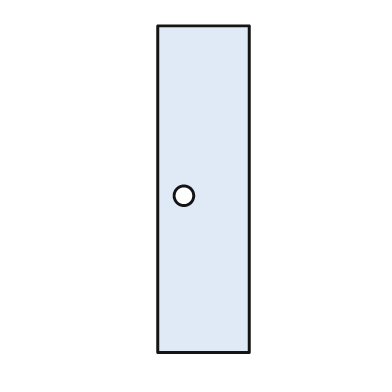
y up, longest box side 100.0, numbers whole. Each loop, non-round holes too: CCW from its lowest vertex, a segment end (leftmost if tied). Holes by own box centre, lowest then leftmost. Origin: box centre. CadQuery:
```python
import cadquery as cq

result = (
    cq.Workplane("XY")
    .moveTo(-14.0, -50.0)
    .lineTo(14.0, -50.0)
    .lineTo(14.0, 50.0)
    .lineTo(-14.0, 50.0)
    .close()
    .moveTo(-6.0, -2.0)
    .circle(3.0)
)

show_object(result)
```